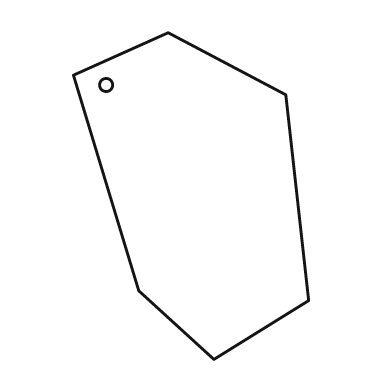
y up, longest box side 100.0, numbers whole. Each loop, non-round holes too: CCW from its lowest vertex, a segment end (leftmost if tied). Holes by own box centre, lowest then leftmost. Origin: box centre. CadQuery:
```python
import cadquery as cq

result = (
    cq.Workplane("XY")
    .moveTo(7.0, -50.0)
    .lineTo(36.0, -32.0)
    .lineTo(29.0, 31.0)
    .lineTo(-7.0, 50.0)
    .lineTo(-36.0, 37.0)
    .lineTo(-16.0, -29.0)
    .close()
    .moveTo(-26.0, 34.0)
    .circle(2.0)
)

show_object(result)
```